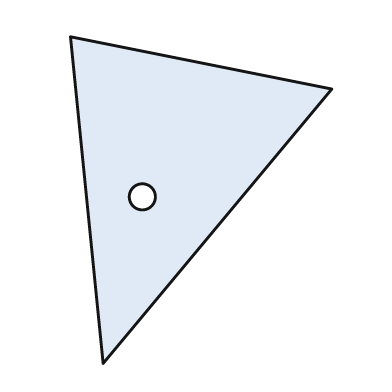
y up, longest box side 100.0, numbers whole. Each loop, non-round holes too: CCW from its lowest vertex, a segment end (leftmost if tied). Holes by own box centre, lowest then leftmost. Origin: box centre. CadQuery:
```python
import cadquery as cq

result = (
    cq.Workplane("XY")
    .moveTo(-30.0, -50.0)
    .lineTo(40.0, 34.0)
    .lineTo(-40.0, 50.0)
    .close()
    .moveTo(-18.0, 1.0)
    .circle(4.0)
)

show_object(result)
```